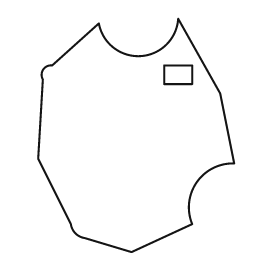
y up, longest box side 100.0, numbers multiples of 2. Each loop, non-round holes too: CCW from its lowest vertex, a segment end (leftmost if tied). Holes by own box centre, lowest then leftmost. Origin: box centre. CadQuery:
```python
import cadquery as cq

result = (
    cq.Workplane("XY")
    .moveTo(-2.0, -50.0)
    .lineTo(24.0, -38.0)
    .threePointArc((26.0, -20.0), (42.0, -12.0))
    .lineTo(36.0, 18.0)
    .lineTo(18.0, 50.0)
    .threePointArc((2.0, 34.0), (-16.0, 48.0))
    .lineTo(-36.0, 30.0)
    .threePointArc((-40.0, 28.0), (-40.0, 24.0))
    .lineTo(-42.0, -10.0)
    .lineTo(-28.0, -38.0)
    .threePointArc((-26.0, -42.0), (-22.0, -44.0))
    .close()
    .moveTo(12.0, 22.0)
    .lineTo(24.0, 22.0)
    .lineTo(24.0, 30.0)
    .lineTo(12.0, 30.0)
    .close()
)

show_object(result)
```